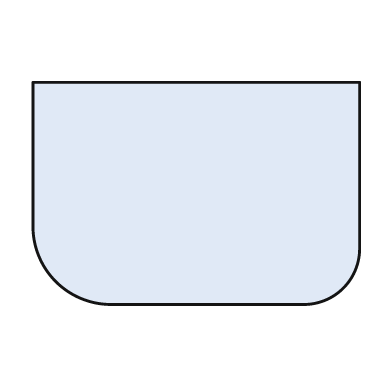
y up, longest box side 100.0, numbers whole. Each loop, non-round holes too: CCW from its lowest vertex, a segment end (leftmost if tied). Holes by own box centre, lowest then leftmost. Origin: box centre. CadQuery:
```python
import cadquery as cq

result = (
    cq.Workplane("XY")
    .moveTo(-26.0, -34.0)
    .lineTo(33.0, -34.0)
    .threePointArc((45.0, -29.0), (50.0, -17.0))
    .lineTo(50.0, 34.0)
    .lineTo(-50.0, 34.0)
    .lineTo(-50.0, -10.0)
    .threePointArc((-43.0, -27.0), (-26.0, -34.0))
    .close()
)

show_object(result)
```